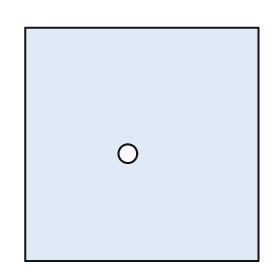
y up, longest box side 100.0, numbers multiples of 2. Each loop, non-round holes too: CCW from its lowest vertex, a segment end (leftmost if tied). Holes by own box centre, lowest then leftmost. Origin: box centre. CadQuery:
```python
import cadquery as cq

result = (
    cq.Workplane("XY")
    .moveTo(-50.0, -50.0)
    .lineTo(50.0, -50.0)
    .lineTo(50.0, 50.0)
    .lineTo(-50.0, 50.0)
    .close()
    .moveTo(-6.0, -4.0)
    .circle(4.0)
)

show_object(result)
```